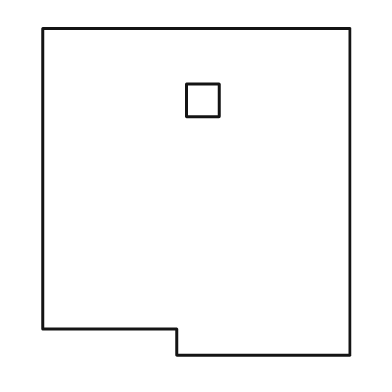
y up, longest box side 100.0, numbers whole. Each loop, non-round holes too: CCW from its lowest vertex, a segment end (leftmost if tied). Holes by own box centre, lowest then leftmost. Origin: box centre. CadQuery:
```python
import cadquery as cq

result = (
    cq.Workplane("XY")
    .moveTo(-6.0, -50.0)
    .lineTo(47.0, -50.0)
    .lineTo(47.0, 50.0)
    .lineTo(-47.0, 50.0)
    .lineTo(-47.0, -42.0)
    .lineTo(-6.0, -42.0)
    .close()
    .moveTo(-3.0, 23.0)
    .lineTo(7.0, 23.0)
    .lineTo(7.0, 33.0)
    .lineTo(-3.0, 33.0)
    .close()
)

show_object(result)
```